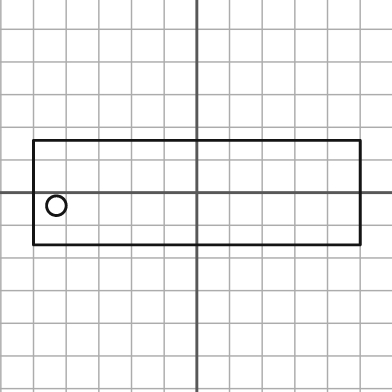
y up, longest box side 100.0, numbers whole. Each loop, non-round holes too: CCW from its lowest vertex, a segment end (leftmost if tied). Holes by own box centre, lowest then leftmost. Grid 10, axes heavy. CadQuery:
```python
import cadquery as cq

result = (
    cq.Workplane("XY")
    .moveTo(-50.0, -16.0)
    .lineTo(50.0, -16.0)
    .lineTo(50.0, 16.0)
    .lineTo(-50.0, 16.0)
    .close()
    .moveTo(-43.0, -4.0)
    .circle(3.0)
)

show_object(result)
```